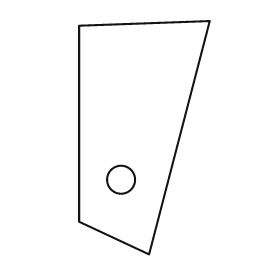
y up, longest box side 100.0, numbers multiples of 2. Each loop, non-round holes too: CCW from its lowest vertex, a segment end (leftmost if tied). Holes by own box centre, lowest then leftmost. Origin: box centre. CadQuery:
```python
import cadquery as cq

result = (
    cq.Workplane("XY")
    .moveTo(2.0, -50.0)
    .lineTo(28.0, 50.0)
    .lineTo(-28.0, 48.0)
    .lineTo(-28.0, -36.0)
    .close()
    .moveTo(-10.0, -18.0)
    .circle(6.0)
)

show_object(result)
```